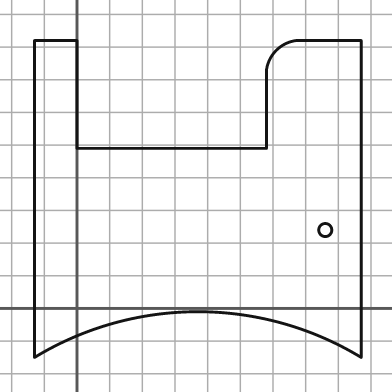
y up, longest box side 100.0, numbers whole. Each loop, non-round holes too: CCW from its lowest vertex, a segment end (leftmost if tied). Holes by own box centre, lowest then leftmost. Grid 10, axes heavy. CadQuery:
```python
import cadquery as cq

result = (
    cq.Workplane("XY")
    .moveTo(-13.0, -15.0)
    .threePointArc((37.0, -1.0), (87.0, -15.0))
    .lineTo(87.0, 82.0)
    .lineTo(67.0, 82.0)
    .threePointArc((61.0, 79.0), (58.0, 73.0))
    .lineTo(58.0, 49.0)
    .lineTo(0.0, 49.0)
    .lineTo(0.0, 82.0)
    .lineTo(-13.0, 82.0)
    .close()
    .moveTo(76.0, 24.0)
    .circle(2.0)
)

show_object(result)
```